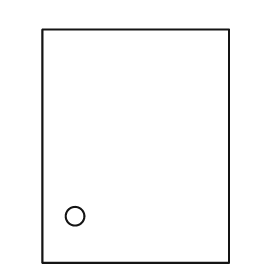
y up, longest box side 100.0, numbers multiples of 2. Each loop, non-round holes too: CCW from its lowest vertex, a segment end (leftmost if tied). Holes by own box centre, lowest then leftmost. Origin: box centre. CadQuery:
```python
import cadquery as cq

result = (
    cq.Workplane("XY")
    .moveTo(-40.0, -50.0)
    .lineTo(40.0, -50.0)
    .lineTo(40.0, 50.0)
    .lineTo(-40.0, 50.0)
    .close()
    .moveTo(-26.0, -30.0)
    .circle(4.0)
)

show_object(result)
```